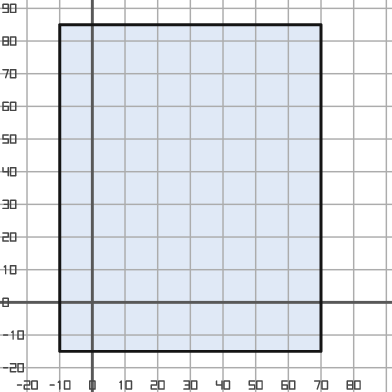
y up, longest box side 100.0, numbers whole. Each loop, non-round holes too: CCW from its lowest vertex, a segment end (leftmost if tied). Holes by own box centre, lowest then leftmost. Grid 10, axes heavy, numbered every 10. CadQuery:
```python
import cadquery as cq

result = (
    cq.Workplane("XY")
    .moveTo(-10.0, -15.0)
    .lineTo(70.0, -15.0)
    .lineTo(70.0, 85.0)
    .lineTo(-10.0, 85.0)
    .close()
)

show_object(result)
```